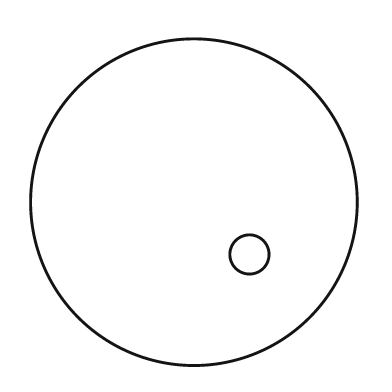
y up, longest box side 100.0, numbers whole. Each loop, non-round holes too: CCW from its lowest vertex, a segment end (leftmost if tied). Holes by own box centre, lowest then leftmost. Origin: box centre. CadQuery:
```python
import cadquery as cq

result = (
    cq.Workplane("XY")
    .moveTo(0.0, 0.0)
    .circle(50.0)
    .moveTo(17.0, -16.0)
    .circle(6.0)
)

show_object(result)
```